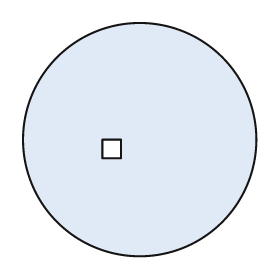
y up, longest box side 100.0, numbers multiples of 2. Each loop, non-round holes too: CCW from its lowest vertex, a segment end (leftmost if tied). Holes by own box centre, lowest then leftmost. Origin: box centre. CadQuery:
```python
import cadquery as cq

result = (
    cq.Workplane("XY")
    .moveTo(0.0, 0.0)
    .circle(50.0)
    .moveTo(-16.0, -8.0)
    .lineTo(-8.0, -8.0)
    .lineTo(-8.0, 0.0)
    .lineTo(-16.0, 0.0)
    .close()
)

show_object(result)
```